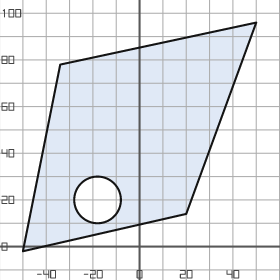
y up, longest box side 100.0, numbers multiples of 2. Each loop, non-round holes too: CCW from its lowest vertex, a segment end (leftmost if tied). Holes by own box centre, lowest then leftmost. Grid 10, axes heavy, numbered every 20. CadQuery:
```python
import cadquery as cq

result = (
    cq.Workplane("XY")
    .moveTo(-50.0, -2.0)
    .lineTo(20.0, 14.0)
    .lineTo(50.0, 96.0)
    .lineTo(-34.0, 78.0)
    .close()
    .moveTo(-18.0, 20.0)
    .circle(10.0)
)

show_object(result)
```